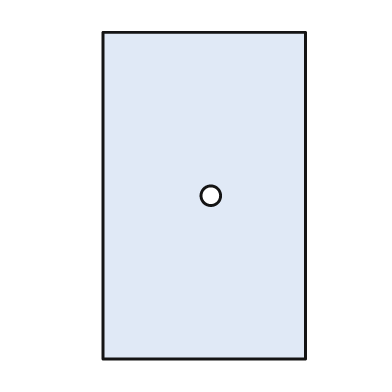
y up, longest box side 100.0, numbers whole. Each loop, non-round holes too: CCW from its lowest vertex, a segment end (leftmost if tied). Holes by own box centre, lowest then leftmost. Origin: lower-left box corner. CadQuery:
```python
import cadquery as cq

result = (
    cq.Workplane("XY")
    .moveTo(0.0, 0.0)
    .lineTo(62.0, 0.0)
    .lineTo(62.0, 100.0)
    .lineTo(0.0, 100.0)
    .close()
    .moveTo(33.0, 50.0)
    .circle(3.0)
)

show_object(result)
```